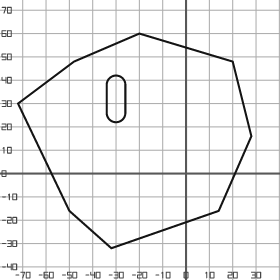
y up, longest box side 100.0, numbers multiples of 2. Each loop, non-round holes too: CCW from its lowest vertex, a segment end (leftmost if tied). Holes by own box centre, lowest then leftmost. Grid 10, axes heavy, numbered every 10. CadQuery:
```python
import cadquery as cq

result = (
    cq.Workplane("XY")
    .moveTo(-32.0, -32.0)
    .lineTo(14.0, -16.0)
    .lineTo(28.0, 16.0)
    .lineTo(20.0, 48.0)
    .lineTo(-20.0, 60.0)
    .lineTo(-48.0, 48.0)
    .lineTo(-72.0, 30.0)
    .lineTo(-50.0, -16.0)
    .close()
    .moveTo(-34.0, 26.0)
    .threePointArc((-30.0, 22.0), (-26.0, 26.0))
    .lineTo(-26.0, 38.0)
    .threePointArc((-30.0, 42.0), (-34.0, 38.0))
    .close()
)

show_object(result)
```